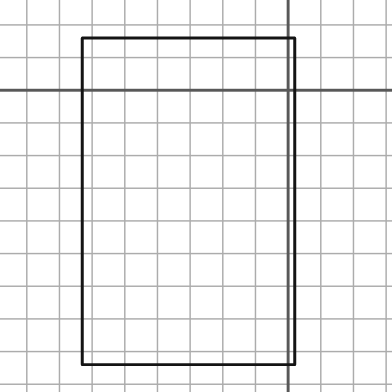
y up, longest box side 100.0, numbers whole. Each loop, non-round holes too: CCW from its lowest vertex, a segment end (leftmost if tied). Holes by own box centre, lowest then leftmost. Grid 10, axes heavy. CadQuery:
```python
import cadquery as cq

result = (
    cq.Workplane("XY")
    .moveTo(-63.0, -84.0)
    .lineTo(2.0, -84.0)
    .lineTo(2.0, 16.0)
    .lineTo(-63.0, 16.0)
    .close()
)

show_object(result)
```